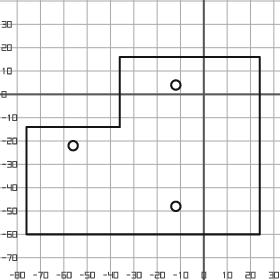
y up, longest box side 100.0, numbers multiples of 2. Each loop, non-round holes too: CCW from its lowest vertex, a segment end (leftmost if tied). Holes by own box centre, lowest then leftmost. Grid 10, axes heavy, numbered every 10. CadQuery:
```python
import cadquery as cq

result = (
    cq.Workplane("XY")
    .moveTo(-76.0, -60.0)
    .lineTo(24.0, -60.0)
    .lineTo(24.0, 16.0)
    .lineTo(-36.0, 16.0)
    .lineTo(-36.0, -14.0)
    .lineTo(-76.0, -14.0)
    .close()
    .moveTo(-12.0, -48.0)
    .circle(2.0)
    .moveTo(-56.0, -22.0)
    .circle(2.0)
    .moveTo(-12.0, 4.0)
    .circle(2.0)
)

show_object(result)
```